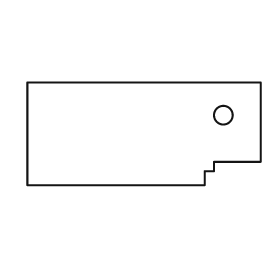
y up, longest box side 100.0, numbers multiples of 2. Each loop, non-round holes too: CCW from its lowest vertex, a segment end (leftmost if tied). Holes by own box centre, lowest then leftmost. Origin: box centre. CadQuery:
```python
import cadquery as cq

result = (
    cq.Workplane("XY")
    .moveTo(-50.0, -22.0)
    .lineTo(26.0, -22.0)
    .lineTo(26.0, -16.0)
    .lineTo(30.0, -16.0)
    .lineTo(30.0, -12.0)
    .lineTo(50.0, -12.0)
    .lineTo(50.0, 22.0)
    .lineTo(-50.0, 22.0)
    .close()
    .moveTo(34.0, 8.0)
    .circle(4.0)
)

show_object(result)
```